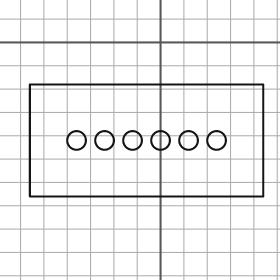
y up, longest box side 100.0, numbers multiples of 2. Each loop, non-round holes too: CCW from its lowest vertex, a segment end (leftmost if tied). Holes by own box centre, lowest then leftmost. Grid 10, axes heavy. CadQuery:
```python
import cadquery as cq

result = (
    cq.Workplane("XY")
    .moveTo(-56.0, -66.0)
    .lineTo(44.0, -66.0)
    .lineTo(44.0, -18.0)
    .lineTo(-56.0, -18.0)
    .close()
    .moveTo(-36.0, -42.0)
    .circle(4.0)
    .moveTo(-24.0, -42.0)
    .circle(4.0)
    .moveTo(-12.0, -42.0)
    .circle(4.0)
    .moveTo(0.0, -42.0)
    .circle(4.0)
    .moveTo(12.0, -42.0)
    .circle(4.0)
    .moveTo(24.0, -42.0)
    .circle(4.0)
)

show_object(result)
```